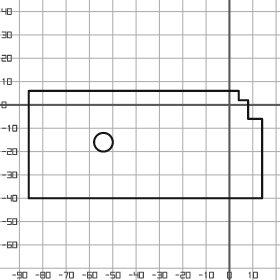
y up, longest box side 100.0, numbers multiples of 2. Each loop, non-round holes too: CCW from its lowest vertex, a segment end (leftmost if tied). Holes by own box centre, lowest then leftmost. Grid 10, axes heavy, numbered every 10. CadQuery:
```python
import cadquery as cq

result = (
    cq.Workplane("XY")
    .moveTo(-86.0, -40.0)
    .lineTo(14.0, -40.0)
    .lineTo(14.0, -6.0)
    .lineTo(8.0, -6.0)
    .lineTo(8.0, 2.0)
    .lineTo(4.0, 2.0)
    .lineTo(4.0, 6.0)
    .lineTo(-86.0, 6.0)
    .close()
    .moveTo(-54.0, -16.0)
    .circle(4.0)
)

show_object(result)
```